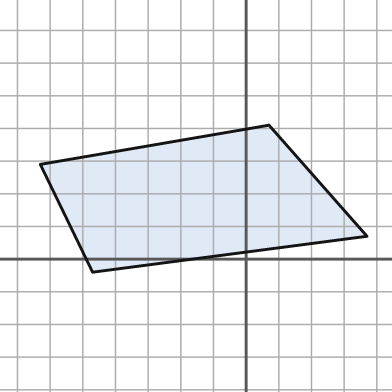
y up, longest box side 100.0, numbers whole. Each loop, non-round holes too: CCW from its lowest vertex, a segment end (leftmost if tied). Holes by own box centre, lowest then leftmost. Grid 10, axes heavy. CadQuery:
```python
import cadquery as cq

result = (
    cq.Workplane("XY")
    .moveTo(-47.0, -4.0)
    .lineTo(37.0, 7.0)
    .lineTo(7.0, 41.0)
    .lineTo(-63.0, 29.0)
    .close()
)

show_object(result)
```